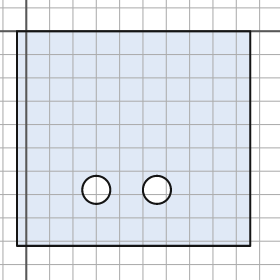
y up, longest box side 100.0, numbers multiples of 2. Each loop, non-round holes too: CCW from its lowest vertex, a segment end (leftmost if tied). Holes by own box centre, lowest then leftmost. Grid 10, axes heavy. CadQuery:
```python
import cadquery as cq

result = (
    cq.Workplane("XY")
    .moveTo(-4.0, -92.0)
    .lineTo(96.0, -92.0)
    .lineTo(96.0, 0.0)
    .lineTo(-4.0, 0.0)
    .close()
    .moveTo(30.0, -68.0)
    .circle(6.0)
    .moveTo(56.0, -68.0)
    .circle(6.0)
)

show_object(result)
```